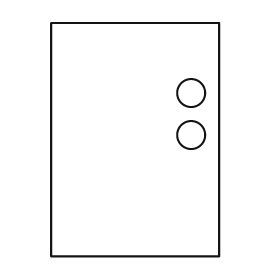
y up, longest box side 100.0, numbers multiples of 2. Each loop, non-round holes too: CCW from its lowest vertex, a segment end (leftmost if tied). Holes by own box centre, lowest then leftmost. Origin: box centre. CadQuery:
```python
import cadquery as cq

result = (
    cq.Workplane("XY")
    .moveTo(-36.0, -50.0)
    .lineTo(36.0, -50.0)
    .lineTo(36.0, 50.0)
    .lineTo(-36.0, 50.0)
    .close()
    .moveTo(24.0, 2.0)
    .circle(6.0)
    .moveTo(24.0, 20.0)
    .circle(6.0)
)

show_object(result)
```